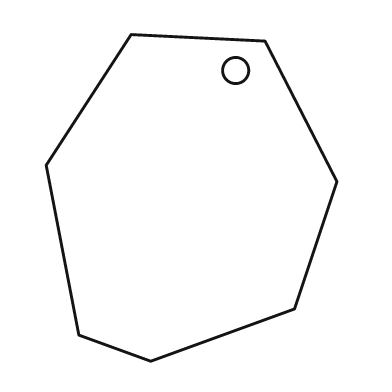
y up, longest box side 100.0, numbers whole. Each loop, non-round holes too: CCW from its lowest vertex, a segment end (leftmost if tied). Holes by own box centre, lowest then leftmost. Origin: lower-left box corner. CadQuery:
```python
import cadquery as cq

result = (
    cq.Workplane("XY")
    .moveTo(32.0, 0.0)
    .lineTo(76.0, 16.0)
    .lineTo(89.0, 55.0)
    .lineTo(67.0, 98.0)
    .lineTo(26.0, 100.0)
    .lineTo(0.0, 60.0)
    .lineTo(10.0, 8.0)
    .close()
    .moveTo(58.0, 89.0)
    .circle(4.0)
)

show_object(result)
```